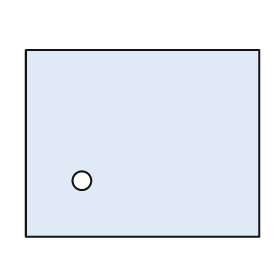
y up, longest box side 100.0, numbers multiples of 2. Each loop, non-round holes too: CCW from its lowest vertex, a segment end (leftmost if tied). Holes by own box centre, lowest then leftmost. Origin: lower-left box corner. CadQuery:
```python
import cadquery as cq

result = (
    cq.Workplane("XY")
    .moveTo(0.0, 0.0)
    .lineTo(100.0, 0.0)
    .lineTo(100.0, 80.0)
    .lineTo(0.0, 80.0)
    .close()
    .moveTo(24.0, 24.0)
    .circle(4.0)
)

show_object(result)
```